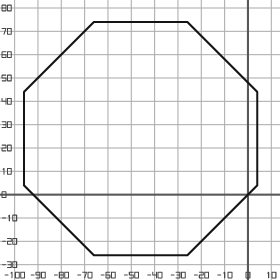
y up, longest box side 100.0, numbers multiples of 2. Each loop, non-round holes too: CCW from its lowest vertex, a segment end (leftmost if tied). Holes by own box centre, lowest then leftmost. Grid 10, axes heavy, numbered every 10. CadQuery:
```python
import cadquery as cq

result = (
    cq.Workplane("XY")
    .moveTo(-66.0, -26.0)
    .lineTo(-26.0, -26.0)
    .lineTo(4.0, 4.0)
    .lineTo(4.0, 44.0)
    .lineTo(-26.0, 74.0)
    .lineTo(-66.0, 74.0)
    .lineTo(-96.0, 44.0)
    .lineTo(-96.0, 4.0)
    .close()
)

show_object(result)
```